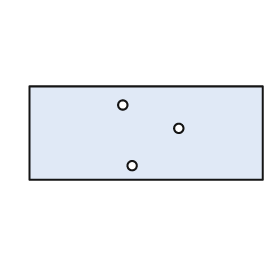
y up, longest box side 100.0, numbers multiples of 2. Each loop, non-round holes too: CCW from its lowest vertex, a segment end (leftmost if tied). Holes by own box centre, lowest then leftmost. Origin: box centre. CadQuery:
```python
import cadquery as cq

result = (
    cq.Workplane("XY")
    .moveTo(-50.0, -20.0)
    .lineTo(50.0, -20.0)
    .lineTo(50.0, 20.0)
    .lineTo(-50.0, 20.0)
    .close()
    .moveTo(-6.0, -14.0)
    .circle(2.0)
    .moveTo(14.0, 2.0)
    .circle(2.0)
    .moveTo(-10.0, 12.0)
    .circle(2.0)
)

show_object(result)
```